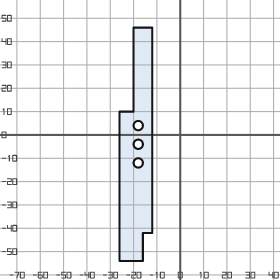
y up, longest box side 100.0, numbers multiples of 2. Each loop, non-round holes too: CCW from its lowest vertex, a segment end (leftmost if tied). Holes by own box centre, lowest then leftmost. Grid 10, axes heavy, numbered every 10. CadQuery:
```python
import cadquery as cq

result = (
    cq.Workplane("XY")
    .moveTo(-26.0, -54.0)
    .lineTo(-16.0, -54.0)
    .lineTo(-16.0, -42.0)
    .lineTo(-12.0, -42.0)
    .lineTo(-12.0, 46.0)
    .lineTo(-20.0, 46.0)
    .lineTo(-20.0, 10.0)
    .lineTo(-26.0, 10.0)
    .close()
    .moveTo(-18.0, -12.0)
    .circle(2.0)
    .moveTo(-18.0, -4.0)
    .circle(2.0)
    .moveTo(-18.0, 4.0)
    .circle(2.0)
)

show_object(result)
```